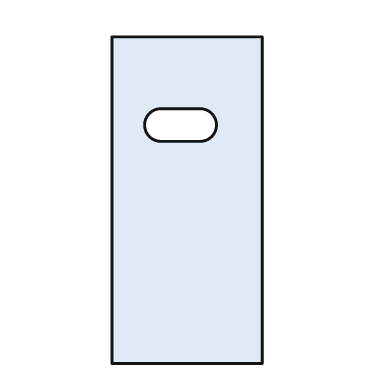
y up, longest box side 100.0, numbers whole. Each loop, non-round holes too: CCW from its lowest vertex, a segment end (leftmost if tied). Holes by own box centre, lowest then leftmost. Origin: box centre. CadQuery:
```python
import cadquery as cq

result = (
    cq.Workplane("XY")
    .moveTo(-23.0, -50.0)
    .lineTo(23.0, -50.0)
    .lineTo(23.0, 50.0)
    .lineTo(-23.0, 50.0)
    .close()
    .moveTo(-8.0, 18.0)
    .lineTo(4.0, 18.0)
    .threePointArc((9.0, 23.0), (4.0, 28.0))
    .lineTo(-8.0, 28.0)
    .threePointArc((-13.0, 23.0), (-8.0, 18.0))
    .close()
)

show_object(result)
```